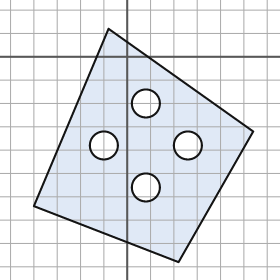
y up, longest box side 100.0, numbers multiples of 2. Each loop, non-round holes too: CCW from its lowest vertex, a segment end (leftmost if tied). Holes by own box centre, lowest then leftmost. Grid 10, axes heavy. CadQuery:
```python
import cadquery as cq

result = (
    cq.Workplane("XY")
    .moveTo(22.0, -88.0)
    .lineTo(54.0, -32.0)
    .lineTo(-8.0, 12.0)
    .lineTo(-40.0, -64.0)
    .close()
    .moveTo(8.0, -56.0)
    .circle(6.0)
    .moveTo(-10.0, -38.0)
    .circle(6.0)
    .moveTo(26.0, -38.0)
    .circle(6.0)
    .moveTo(8.0, -20.0)
    .circle(6.0)
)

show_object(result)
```